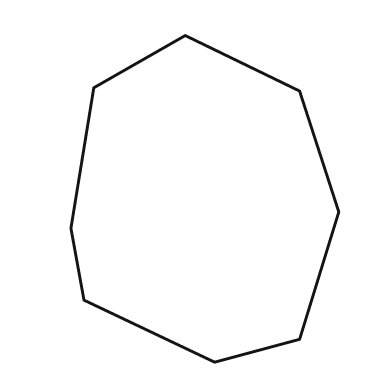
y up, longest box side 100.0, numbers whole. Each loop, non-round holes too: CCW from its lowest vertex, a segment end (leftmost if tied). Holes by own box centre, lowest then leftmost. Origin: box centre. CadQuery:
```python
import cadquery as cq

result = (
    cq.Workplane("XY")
    .moveTo(3.0, -50.0)
    .lineTo(29.0, -43.0)
    .lineTo(41.0, -4.0)
    .lineTo(29.0, 33.0)
    .lineTo(-6.0, 50.0)
    .lineTo(-34.0, 34.0)
    .lineTo(-41.0, -9.0)
    .lineTo(-37.0, -31.0)
    .close()
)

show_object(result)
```